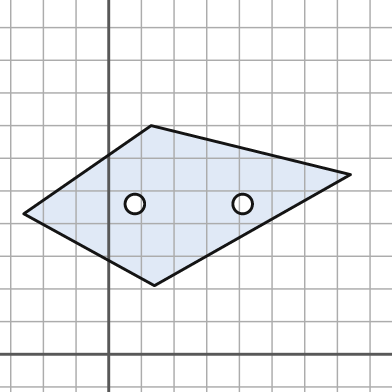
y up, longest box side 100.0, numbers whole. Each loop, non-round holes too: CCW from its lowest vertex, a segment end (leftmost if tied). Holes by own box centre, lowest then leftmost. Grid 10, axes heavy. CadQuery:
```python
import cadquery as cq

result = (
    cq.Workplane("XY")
    .moveTo(14.0, 21.0)
    .lineTo(74.0, 55.0)
    .lineTo(13.0, 70.0)
    .lineTo(-26.0, 43.0)
    .close()
    .moveTo(8.0, 46.0)
    .circle(3.0)
    .moveTo(41.0, 46.0)
    .circle(3.0)
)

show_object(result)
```